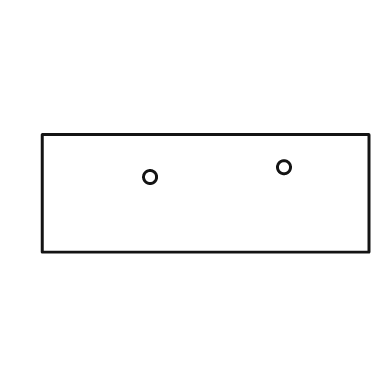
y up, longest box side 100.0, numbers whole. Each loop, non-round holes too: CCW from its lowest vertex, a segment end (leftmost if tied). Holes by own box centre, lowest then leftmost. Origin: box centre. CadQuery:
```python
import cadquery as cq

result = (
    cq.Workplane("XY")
    .moveTo(-50.0, -18.0)
    .lineTo(50.0, -18.0)
    .lineTo(50.0, 18.0)
    .lineTo(-50.0, 18.0)
    .close()
    .moveTo(-17.0, 5.0)
    .circle(2.0)
    .moveTo(24.0, 8.0)
    .circle(2.0)
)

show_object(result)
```